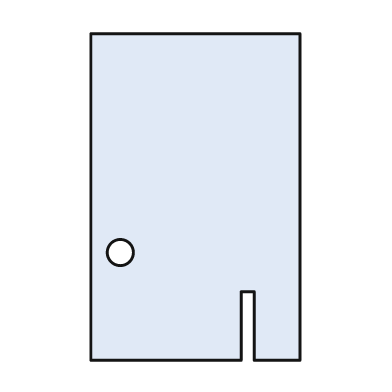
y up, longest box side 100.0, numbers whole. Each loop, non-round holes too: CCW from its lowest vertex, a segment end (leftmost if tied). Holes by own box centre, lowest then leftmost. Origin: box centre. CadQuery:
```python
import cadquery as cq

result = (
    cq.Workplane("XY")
    .moveTo(-32.0, -50.0)
    .lineTo(14.0, -50.0)
    .lineTo(14.0, -29.0)
    .lineTo(18.0, -29.0)
    .lineTo(18.0, -50.0)
    .lineTo(32.0, -50.0)
    .lineTo(32.0, 50.0)
    .lineTo(-32.0, 50.0)
    .close()
    .moveTo(-23.0, -17.0)
    .circle(4.0)
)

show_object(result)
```